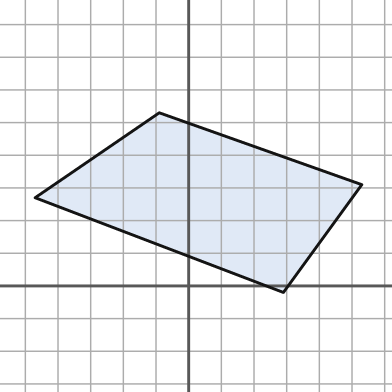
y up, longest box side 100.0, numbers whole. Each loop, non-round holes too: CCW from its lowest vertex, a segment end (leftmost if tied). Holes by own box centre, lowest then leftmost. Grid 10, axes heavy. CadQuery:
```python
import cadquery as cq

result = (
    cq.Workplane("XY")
    .moveTo(29.0, -2.0)
    .lineTo(53.0, 31.0)
    .lineTo(-9.0, 53.0)
    .lineTo(-47.0, 27.0)
    .close()
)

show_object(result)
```